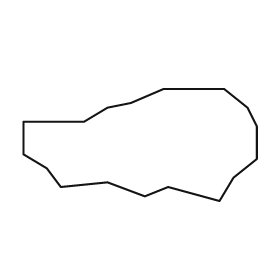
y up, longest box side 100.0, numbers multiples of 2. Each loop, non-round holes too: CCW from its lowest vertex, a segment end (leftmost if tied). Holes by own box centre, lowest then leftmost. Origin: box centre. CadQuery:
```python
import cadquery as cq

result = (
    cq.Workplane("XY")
    .moveTo(34.0, -24.0)
    .lineTo(40.0, -14.0)
    .lineTo(50.0, -6.0)
    .lineTo(50.0, 8.0)
    .lineTo(46.0, 16.0)
    .lineTo(36.0, 24.0)
    .lineTo(10.0, 24.0)
    .lineTo(-4.0, 18.0)
    .lineTo(-14.0, 16.0)
    .lineTo(-24.0, 10.0)
    .lineTo(-50.0, 10.0)
    .lineTo(-50.0, -4.0)
    .lineTo(-40.0, -10.0)
    .lineTo(-34.0, -18.0)
    .lineTo(-14.0, -16.0)
    .lineTo(2.0, -22.0)
    .lineTo(12.0, -18.0)
    .close()
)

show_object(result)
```